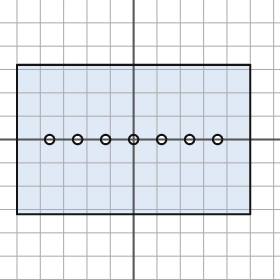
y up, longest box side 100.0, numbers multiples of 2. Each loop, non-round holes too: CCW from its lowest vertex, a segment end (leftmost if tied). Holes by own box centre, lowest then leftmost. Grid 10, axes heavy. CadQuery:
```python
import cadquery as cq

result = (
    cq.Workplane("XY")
    .moveTo(-50.0, -32.0)
    .lineTo(50.0, -32.0)
    .lineTo(50.0, 32.0)
    .lineTo(-50.0, 32.0)
    .close()
    .moveTo(-36.0, 0.0)
    .circle(2.0)
    .moveTo(-24.0, 0.0)
    .circle(2.0)
    .moveTo(-12.0, 0.0)
    .circle(2.0)
    .moveTo(0.0, 0.0)
    .circle(2.0)
    .moveTo(12.0, 0.0)
    .circle(2.0)
    .moveTo(24.0, 0.0)
    .circle(2.0)
    .moveTo(36.0, 0.0)
    .circle(2.0)
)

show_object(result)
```